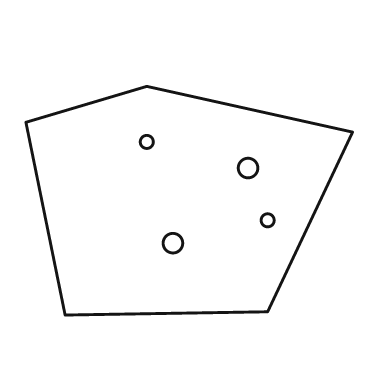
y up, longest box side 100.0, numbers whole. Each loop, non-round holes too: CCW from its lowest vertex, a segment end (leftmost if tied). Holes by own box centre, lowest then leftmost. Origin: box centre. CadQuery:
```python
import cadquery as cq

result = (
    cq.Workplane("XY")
    .moveTo(-38.0, -35.0)
    .lineTo(24.0, -34.0)
    .lineTo(50.0, 21.0)
    .lineTo(-13.0, 35.0)
    .lineTo(-50.0, 24.0)
    .close()
    .moveTo(-5.0, -13.0)
    .circle(3.0)
    .moveTo(24.0, -6.0)
    .circle(2.0)
    .moveTo(18.0, 10.0)
    .circle(3.0)
    .moveTo(-13.0, 18.0)
    .circle(2.0)
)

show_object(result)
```